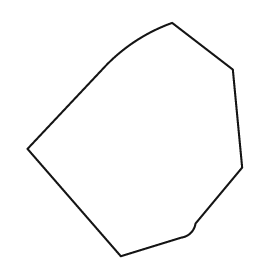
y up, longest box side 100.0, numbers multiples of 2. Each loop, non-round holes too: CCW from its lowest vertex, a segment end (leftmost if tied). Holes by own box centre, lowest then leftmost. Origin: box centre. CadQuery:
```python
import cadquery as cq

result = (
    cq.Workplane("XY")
    .moveTo(-6.0, -50.0)
    .lineTo(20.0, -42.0)
    .threePointArc((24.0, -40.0), (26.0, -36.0))
    .lineTo(46.0, -12.0)
    .lineTo(42.0, 30.0)
    .lineTo(16.0, 50.0)
    .threePointArc((0.0, 42.0), (-14.0, 30.0))
    .lineTo(-46.0, -4.0)
    .close()
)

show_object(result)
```